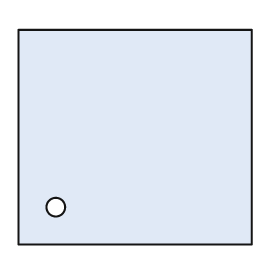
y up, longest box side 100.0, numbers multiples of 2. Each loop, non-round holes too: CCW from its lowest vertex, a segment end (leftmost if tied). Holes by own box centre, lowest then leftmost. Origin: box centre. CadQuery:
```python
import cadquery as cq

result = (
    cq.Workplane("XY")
    .moveTo(-50.0, -46.0)
    .lineTo(50.0, -46.0)
    .lineTo(50.0, 46.0)
    .lineTo(-50.0, 46.0)
    .close()
    .moveTo(-34.0, -30.0)
    .circle(4.0)
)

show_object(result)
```